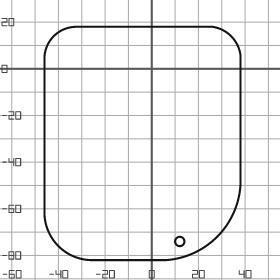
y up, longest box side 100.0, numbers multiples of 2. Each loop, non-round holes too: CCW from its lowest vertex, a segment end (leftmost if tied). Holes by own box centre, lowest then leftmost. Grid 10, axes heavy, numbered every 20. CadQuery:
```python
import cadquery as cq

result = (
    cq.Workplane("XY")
    .moveTo(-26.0, -82.0)
    .lineTo(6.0, -82.0)
    .threePointArc((28.0, -72.0), (38.0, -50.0))
    .lineTo(38.0, 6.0)
    .threePointArc((34.0, 14.0), (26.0, 18.0))
    .lineTo(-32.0, 18.0)
    .threePointArc((-42.0, 14.0), (-46.0, 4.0))
    .lineTo(-46.0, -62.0)
    .threePointArc((-40.0, -76.0), (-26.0, -82.0))
    .close()
    .moveTo(12.0, -74.0)
    .circle(2.0)
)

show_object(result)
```